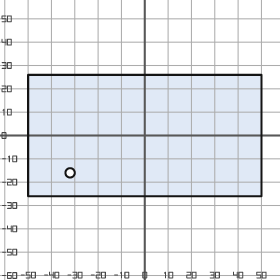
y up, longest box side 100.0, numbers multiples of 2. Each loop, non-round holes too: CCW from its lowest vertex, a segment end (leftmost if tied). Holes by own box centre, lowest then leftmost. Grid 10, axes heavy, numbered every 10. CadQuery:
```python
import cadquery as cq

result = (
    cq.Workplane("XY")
    .moveTo(-50.0, -26.0)
    .lineTo(50.0, -26.0)
    .lineTo(50.0, 26.0)
    .lineTo(-50.0, 26.0)
    .close()
    .moveTo(-32.0, -16.0)
    .circle(2.0)
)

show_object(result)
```